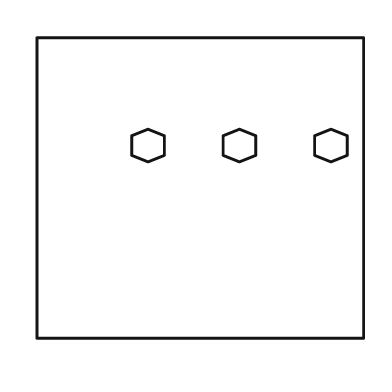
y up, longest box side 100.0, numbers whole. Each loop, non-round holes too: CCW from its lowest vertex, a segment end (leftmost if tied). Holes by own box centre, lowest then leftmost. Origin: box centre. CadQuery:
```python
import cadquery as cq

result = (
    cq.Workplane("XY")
    .moveTo(-50.0, -46.0)
    .lineTo(50.0, -46.0)
    .lineTo(50.0, 46.0)
    .lineTo(-50.0, 46.0)
    .close()
    .moveTo(-16.0, 8.0)
    .lineTo(-11.0, 10.0)
    .lineTo(-11.0, 16.0)
    .lineTo(-16.0, 18.0)
    .lineTo(-21.0, 16.0)
    .lineTo(-21.0, 10.0)
    .close()
    .moveTo(12.0, 8.0)
    .lineTo(17.0, 10.0)
    .lineTo(17.0, 16.0)
    .lineTo(12.0, 18.0)
    .lineTo(7.0, 16.0)
    .lineTo(7.0, 10.0)
    .close()
    .moveTo(40.0, 8.0)
    .lineTo(45.0, 10.0)
    .lineTo(45.0, 16.0)
    .lineTo(40.0, 18.0)
    .lineTo(35.0, 16.0)
    .lineTo(35.0, 10.0)
    .close()
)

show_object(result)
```